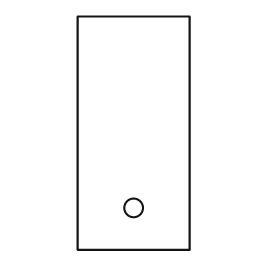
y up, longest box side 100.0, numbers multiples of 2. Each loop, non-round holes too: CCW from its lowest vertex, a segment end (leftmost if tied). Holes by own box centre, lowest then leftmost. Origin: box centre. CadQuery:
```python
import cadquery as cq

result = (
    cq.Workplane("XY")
    .moveTo(-24.0, -50.0)
    .lineTo(24.0, -50.0)
    .lineTo(24.0, 50.0)
    .lineTo(-24.0, 50.0)
    .close()
    .moveTo(0.0, -32.0)
    .circle(4.0)
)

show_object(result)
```